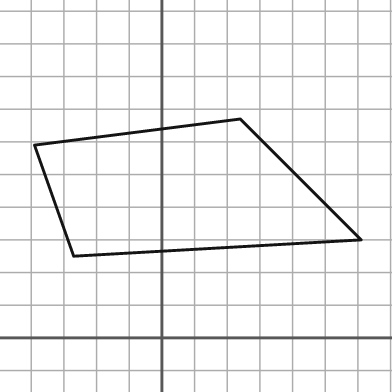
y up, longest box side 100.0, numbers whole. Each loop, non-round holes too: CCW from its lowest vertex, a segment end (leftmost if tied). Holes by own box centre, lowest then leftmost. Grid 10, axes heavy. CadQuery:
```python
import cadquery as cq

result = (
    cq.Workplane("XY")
    .moveTo(-27.0, 25.0)
    .lineTo(61.0, 30.0)
    .lineTo(24.0, 67.0)
    .lineTo(-39.0, 59.0)
    .close()
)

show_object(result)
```